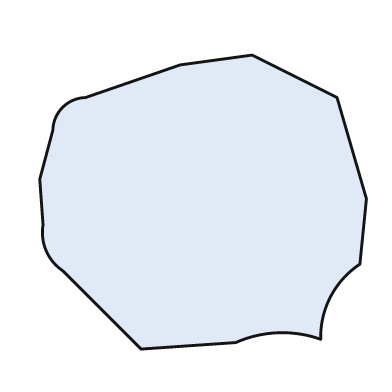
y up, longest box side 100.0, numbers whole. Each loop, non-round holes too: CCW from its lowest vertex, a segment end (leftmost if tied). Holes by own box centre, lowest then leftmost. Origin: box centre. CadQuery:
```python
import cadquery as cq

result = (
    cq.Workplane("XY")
    .moveTo(-19.0, -45.0)
    .lineTo(10.0, -43.0)
    .threePointArc((23.0, -40.0), (36.0, -42.0))
    .threePointArc((39.0, -29.0), (48.0, -19.0))
    .lineTo(50.0, 1.0)
    .lineTo(41.0, 32.0)
    .lineTo(15.0, 45.0)
    .lineTo(-7.0, 42.0)
    .lineTo(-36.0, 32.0)
    .threePointArc((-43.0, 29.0), (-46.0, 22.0))
    .lineTo(-50.0, 7.0)
    .lineTo(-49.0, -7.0)
    .threePointArc((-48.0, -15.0), (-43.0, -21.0))
    .close()
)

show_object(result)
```